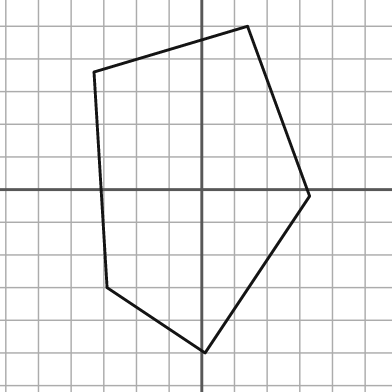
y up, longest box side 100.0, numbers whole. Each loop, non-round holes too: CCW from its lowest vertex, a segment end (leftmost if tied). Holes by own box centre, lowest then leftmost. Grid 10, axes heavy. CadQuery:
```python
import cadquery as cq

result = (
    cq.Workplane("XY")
    .moveTo(1.0, -50.0)
    .lineTo(33.0, -2.0)
    .lineTo(14.0, 50.0)
    .lineTo(-33.0, 36.0)
    .lineTo(-29.0, -30.0)
    .close()
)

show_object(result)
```